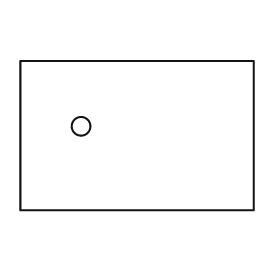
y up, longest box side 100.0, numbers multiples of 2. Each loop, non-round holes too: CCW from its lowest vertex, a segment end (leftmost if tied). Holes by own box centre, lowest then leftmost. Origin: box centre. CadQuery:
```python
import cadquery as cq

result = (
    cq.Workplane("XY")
    .moveTo(-50.0, -32.0)
    .lineTo(50.0, -32.0)
    .lineTo(50.0, 32.0)
    .lineTo(-50.0, 32.0)
    .close()
    .moveTo(-24.0, 4.0)
    .circle(4.0)
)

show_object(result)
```